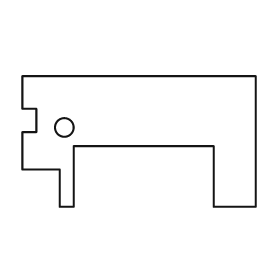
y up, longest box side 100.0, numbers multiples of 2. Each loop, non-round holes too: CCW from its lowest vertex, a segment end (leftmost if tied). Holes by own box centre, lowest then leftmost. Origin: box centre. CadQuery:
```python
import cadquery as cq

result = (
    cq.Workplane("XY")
    .moveTo(-34.0, -28.0)
    .lineTo(-28.0, -28.0)
    .lineTo(-28.0, -2.0)
    .lineTo(32.0, -2.0)
    .lineTo(32.0, -28.0)
    .lineTo(50.0, -28.0)
    .lineTo(50.0, 28.0)
    .lineTo(-50.0, 28.0)
    .lineTo(-50.0, 14.0)
    .lineTo(-44.0, 14.0)
    .lineTo(-44.0, 4.0)
    .lineTo(-50.0, 4.0)
    .lineTo(-50.0, -12.0)
    .lineTo(-34.0, -12.0)
    .close()
    .moveTo(-32.0, 6.0)
    .circle(4.0)
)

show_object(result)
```